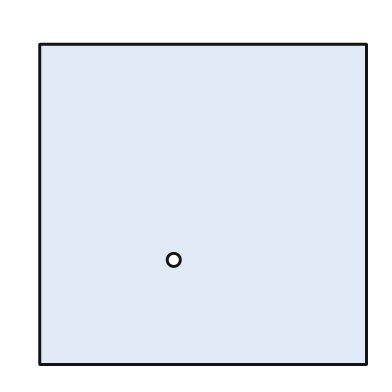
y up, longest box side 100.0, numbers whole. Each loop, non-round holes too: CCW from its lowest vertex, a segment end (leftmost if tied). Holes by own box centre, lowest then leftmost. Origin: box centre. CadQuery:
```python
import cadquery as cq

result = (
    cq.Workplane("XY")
    .moveTo(-50.0, -49.0)
    .lineTo(50.0, -49.0)
    .lineTo(50.0, 49.0)
    .lineTo(-50.0, 49.0)
    .close()
    .moveTo(-9.0, -17.0)
    .circle(2.0)
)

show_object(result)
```